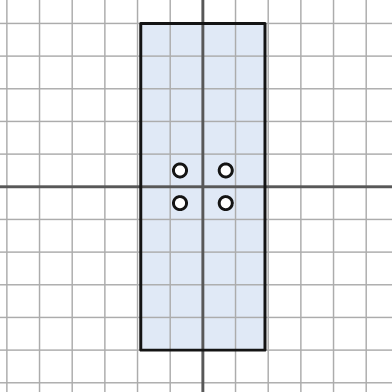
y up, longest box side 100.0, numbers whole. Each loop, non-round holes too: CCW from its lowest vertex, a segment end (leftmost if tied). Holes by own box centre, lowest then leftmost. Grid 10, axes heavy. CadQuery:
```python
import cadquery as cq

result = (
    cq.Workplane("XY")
    .moveTo(-19.0, -50.0)
    .lineTo(19.0, -50.0)
    .lineTo(19.0, 50.0)
    .lineTo(-19.0, 50.0)
    .close()
    .moveTo(-7.0, -5.0)
    .circle(2.0)
    .moveTo(7.0, -5.0)
    .circle(2.0)
    .moveTo(-7.0, 5.0)
    .circle(2.0)
    .moveTo(7.0, 5.0)
    .circle(2.0)
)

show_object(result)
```